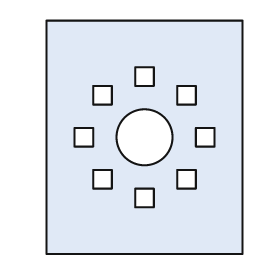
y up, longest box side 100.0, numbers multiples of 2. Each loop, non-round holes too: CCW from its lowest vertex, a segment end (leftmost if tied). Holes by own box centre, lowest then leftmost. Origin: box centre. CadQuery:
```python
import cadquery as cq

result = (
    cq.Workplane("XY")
    .moveTo(-42.0, -50.0)
    .lineTo(42.0, -50.0)
    .lineTo(42.0, 50.0)
    .lineTo(-42.0, 50.0)
    .close()
    .moveTo(-4.0, -30.0)
    .lineTo(4.0, -30.0)
    .lineTo(4.0, -22.0)
    .lineTo(-4.0, -22.0)
    .close()
    .moveTo(-22.0, -22.0)
    .lineTo(-14.0, -22.0)
    .lineTo(-14.0, -14.0)
    .lineTo(-22.0, -14.0)
    .close()
    .moveTo(14.0, -22.0)
    .lineTo(22.0, -22.0)
    .lineTo(22.0, -14.0)
    .lineTo(14.0, -14.0)
    .close()
    .moveTo(-30.0, -4.0)
    .lineTo(-22.0, -4.0)
    .lineTo(-22.0, 4.0)
    .lineTo(-30.0, 4.0)
    .close()
    .moveTo(0.0, 0.0)
    .circle(12.0)
    .moveTo(22.0, -4.0)
    .lineTo(30.0, -4.0)
    .lineTo(30.0, 4.0)
    .lineTo(22.0, 4.0)
    .close()
    .moveTo(-22.0, 14.0)
    .lineTo(-14.0, 14.0)
    .lineTo(-14.0, 22.0)
    .lineTo(-22.0, 22.0)
    .close()
    .moveTo(14.0, 14.0)
    .lineTo(22.0, 14.0)
    .lineTo(22.0, 22.0)
    .lineTo(14.0, 22.0)
    .close()
    .moveTo(-4.0, 22.0)
    .lineTo(4.0, 22.0)
    .lineTo(4.0, 30.0)
    .lineTo(-4.0, 30.0)
    .close()
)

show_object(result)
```